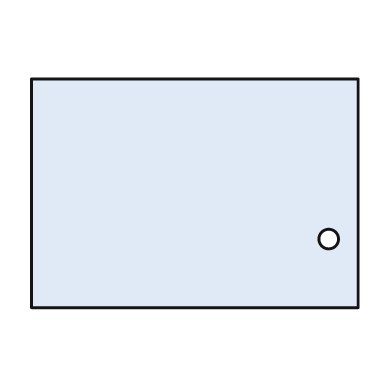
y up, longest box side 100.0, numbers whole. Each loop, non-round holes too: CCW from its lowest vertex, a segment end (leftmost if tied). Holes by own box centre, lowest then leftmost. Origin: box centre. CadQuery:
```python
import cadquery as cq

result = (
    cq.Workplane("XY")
    .moveTo(-50.0, -35.0)
    .lineTo(50.0, -35.0)
    .lineTo(50.0, 35.0)
    .lineTo(-50.0, 35.0)
    .close()
    .moveTo(41.0, -14.0)
    .circle(3.0)
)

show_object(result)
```